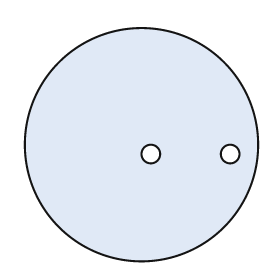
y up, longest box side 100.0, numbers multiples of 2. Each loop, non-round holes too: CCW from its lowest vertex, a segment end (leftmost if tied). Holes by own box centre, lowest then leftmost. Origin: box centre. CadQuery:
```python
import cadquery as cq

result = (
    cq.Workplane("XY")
    .moveTo(0.0, 0.0)
    .circle(50.0)
    .moveTo(4.0, -4.0)
    .circle(4.0)
    .moveTo(38.0, -4.0)
    .circle(4.0)
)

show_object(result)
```